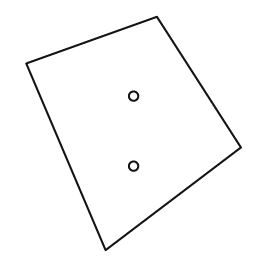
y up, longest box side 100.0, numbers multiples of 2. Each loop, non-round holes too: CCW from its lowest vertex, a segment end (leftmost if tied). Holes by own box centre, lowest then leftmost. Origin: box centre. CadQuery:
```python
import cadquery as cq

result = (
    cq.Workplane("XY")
    .moveTo(-12.0, -50.0)
    .lineTo(46.0, -6.0)
    .lineTo(10.0, 50.0)
    .lineTo(-46.0, 30.0)
    .close()
    .moveTo(0.0, -14.0)
    .circle(2.0)
    .moveTo(0.0, 16.0)
    .circle(2.0)
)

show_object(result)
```